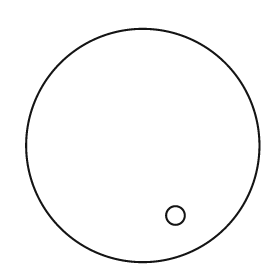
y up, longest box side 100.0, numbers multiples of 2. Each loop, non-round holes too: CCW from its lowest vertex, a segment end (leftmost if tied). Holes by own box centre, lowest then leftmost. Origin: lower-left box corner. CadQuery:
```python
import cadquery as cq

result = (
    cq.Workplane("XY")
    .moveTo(50.0, 50.0)
    .circle(50.0)
    .moveTo(64.0, 20.0)
    .circle(4.0)
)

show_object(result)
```